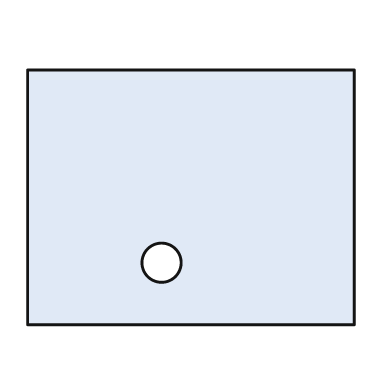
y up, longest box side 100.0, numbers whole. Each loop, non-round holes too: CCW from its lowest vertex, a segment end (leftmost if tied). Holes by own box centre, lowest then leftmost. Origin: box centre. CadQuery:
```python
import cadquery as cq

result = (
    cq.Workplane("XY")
    .moveTo(-50.0, -39.0)
    .lineTo(50.0, -39.0)
    .lineTo(50.0, 39.0)
    .lineTo(-50.0, 39.0)
    .close()
    .moveTo(-9.0, -20.0)
    .circle(6.0)
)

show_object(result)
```